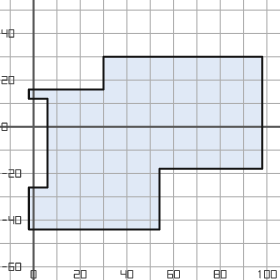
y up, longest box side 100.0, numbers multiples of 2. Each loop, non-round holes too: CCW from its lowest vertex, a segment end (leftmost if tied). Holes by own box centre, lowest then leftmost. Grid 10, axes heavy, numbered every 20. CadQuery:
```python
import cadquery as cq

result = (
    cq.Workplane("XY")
    .moveTo(-2.0, -44.0)
    .lineTo(54.0, -44.0)
    .lineTo(54.0, -18.0)
    .lineTo(98.0, -18.0)
    .lineTo(98.0, 30.0)
    .lineTo(30.0, 30.0)
    .lineTo(30.0, 16.0)
    .lineTo(-2.0, 16.0)
    .lineTo(-2.0, 12.0)
    .lineTo(6.0, 12.0)
    .lineTo(6.0, -26.0)
    .lineTo(-2.0, -26.0)
    .close()
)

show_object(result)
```